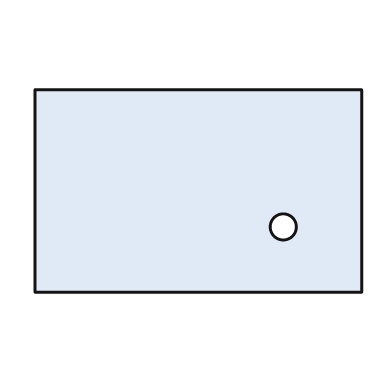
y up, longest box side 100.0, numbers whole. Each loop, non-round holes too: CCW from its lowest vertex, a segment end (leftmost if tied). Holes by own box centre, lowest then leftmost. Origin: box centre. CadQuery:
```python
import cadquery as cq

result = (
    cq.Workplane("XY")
    .moveTo(-50.0, -31.0)
    .lineTo(50.0, -31.0)
    .lineTo(50.0, 31.0)
    .lineTo(-50.0, 31.0)
    .close()
    .moveTo(26.0, -11.0)
    .circle(4.0)
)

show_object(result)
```